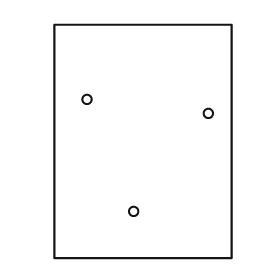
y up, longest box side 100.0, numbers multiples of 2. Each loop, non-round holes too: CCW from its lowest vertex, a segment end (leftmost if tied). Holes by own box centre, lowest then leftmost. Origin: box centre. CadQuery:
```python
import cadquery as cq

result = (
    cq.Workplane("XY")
    .moveTo(-38.0, -50.0)
    .lineTo(38.0, -50.0)
    .lineTo(38.0, 50.0)
    .lineTo(-38.0, 50.0)
    .close()
    .moveTo(-4.0, -30.0)
    .circle(2.0)
    .moveTo(28.0, 12.0)
    .circle(2.0)
    .moveTo(-24.0, 18.0)
    .circle(2.0)
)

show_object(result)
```